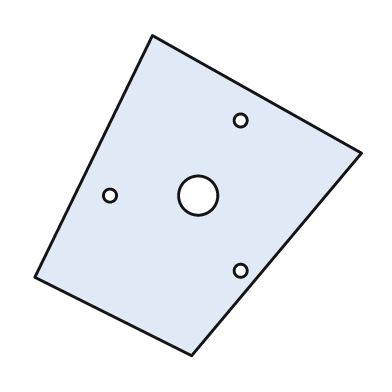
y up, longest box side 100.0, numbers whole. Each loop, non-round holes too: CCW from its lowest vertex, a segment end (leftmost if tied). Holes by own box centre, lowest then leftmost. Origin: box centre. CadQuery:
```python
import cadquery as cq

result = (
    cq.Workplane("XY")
    .moveTo(-2.0, -49.0)
    .lineTo(50.0, 13.0)
    .lineTo(-14.0, 49.0)
    .lineTo(-50.0, -25.0)
    .close()
    .moveTo(13.0, -23.0)
    .circle(2.0)
    .moveTo(-27.0, 0.0)
    .circle(2.0)
    .moveTo(0.0, 0.0)
    .circle(6.0)
    .moveTo(13.0, 23.0)
    .circle(2.0)
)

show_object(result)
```